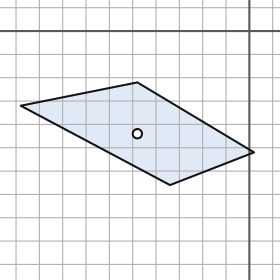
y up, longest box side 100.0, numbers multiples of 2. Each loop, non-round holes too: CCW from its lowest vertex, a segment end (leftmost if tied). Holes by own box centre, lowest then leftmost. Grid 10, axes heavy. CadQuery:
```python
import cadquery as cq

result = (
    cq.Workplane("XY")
    .moveTo(-34.0, -66.0)
    .lineTo(2.0, -52.0)
    .lineTo(-48.0, -22.0)
    .lineTo(-98.0, -32.0)
    .close()
    .moveTo(-48.0, -44.0)
    .circle(2.0)
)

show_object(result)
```